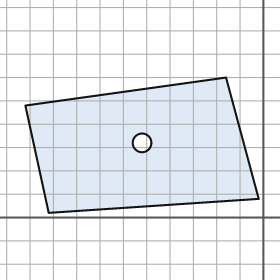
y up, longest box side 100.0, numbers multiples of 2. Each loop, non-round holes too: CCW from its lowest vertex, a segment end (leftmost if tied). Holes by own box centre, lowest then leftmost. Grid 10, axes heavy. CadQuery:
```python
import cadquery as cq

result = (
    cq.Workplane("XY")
    .moveTo(-92.0, 2.0)
    .lineTo(-2.0, 8.0)
    .lineTo(-16.0, 60.0)
    .lineTo(-102.0, 48.0)
    .close()
    .moveTo(-52.0, 32.0)
    .circle(4.0)
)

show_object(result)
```